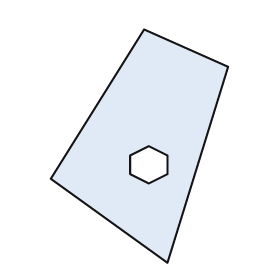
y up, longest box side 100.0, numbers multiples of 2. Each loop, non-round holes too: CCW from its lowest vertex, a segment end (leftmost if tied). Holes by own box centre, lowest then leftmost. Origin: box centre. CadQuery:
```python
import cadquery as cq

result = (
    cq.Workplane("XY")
    .moveTo(12.0, -50.0)
    .lineTo(38.0, 34.0)
    .lineTo(2.0, 50.0)
    .lineTo(-38.0, -14.0)
    .close()
    .moveTo(4.0, -16.0)
    .lineTo(12.0, -12.0)
    .lineTo(12.0, -4.0)
    .lineTo(4.0, 0.0)
    .lineTo(-4.0, -4.0)
    .lineTo(-4.0, -12.0)
    .close()
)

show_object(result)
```